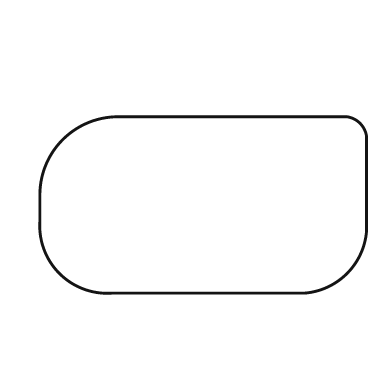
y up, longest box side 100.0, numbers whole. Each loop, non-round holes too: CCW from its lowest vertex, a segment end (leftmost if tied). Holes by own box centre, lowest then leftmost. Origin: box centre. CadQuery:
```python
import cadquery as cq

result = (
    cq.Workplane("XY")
    .moveTo(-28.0, -27.0)
    .lineTo(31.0, -27.0)
    .threePointArc((44.0, -21.0), (50.0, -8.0))
    .lineTo(50.0, 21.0)
    .threePointArc((48.0, 25.0), (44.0, 27.0))
    .lineTo(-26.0, 27.0)
    .threePointArc((-43.0, 20.0), (-50.0, 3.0))
    .lineTo(-50.0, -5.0)
    .threePointArc((-44.0, -21.0), (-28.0, -27.0))
    .close()
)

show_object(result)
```